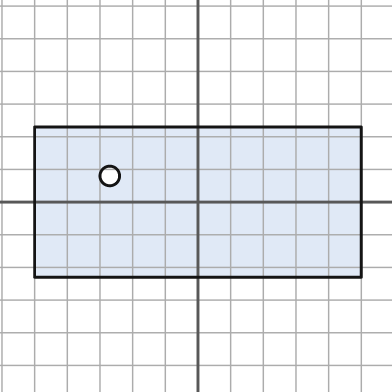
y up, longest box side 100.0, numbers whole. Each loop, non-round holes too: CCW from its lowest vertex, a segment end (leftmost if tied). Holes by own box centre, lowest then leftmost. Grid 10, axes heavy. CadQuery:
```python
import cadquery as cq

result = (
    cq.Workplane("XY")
    .moveTo(-50.0, -23.0)
    .lineTo(50.0, -23.0)
    .lineTo(50.0, 23.0)
    .lineTo(-50.0, 23.0)
    .close()
    .moveTo(-27.0, 8.0)
    .circle(3.0)
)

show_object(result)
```